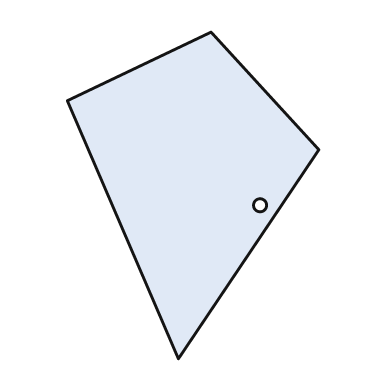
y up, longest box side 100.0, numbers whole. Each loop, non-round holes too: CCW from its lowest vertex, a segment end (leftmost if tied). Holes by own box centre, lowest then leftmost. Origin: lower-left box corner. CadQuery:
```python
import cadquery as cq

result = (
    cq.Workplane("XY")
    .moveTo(34.0, 0.0)
    .lineTo(77.0, 64.0)
    .lineTo(44.0, 100.0)
    .lineTo(0.0, 79.0)
    .close()
    .moveTo(59.0, 47.0)
    .circle(2.0)
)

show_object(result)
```